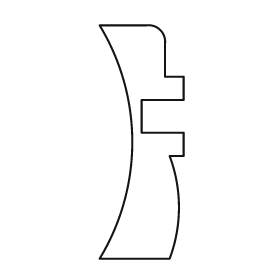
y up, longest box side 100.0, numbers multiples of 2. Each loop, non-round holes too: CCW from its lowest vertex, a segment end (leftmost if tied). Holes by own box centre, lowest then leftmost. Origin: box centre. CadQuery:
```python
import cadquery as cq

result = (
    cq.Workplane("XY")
    .moveTo(-18.0, -50.0)
    .lineTo(12.0, -50.0)
    .threePointArc((16.0, -28.0), (12.0, -6.0))
    .lineTo(18.0, -6.0)
    .lineTo(18.0, 4.0)
    .lineTo(0.0, 4.0)
    .lineTo(0.0, 18.0)
    .lineTo(18.0, 18.0)
    .lineTo(18.0, 28.0)
    .lineTo(10.0, 28.0)
    .lineTo(10.0, 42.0)
    .threePointArc((8.0, 48.0), (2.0, 50.0))
    .lineTo(-18.0, 50.0)
    .threePointArc((-4.0, 0.0), (-18.0, -50.0))
    .close()
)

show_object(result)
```